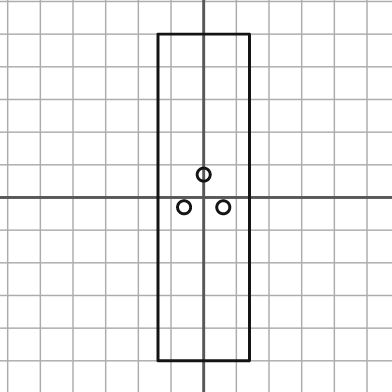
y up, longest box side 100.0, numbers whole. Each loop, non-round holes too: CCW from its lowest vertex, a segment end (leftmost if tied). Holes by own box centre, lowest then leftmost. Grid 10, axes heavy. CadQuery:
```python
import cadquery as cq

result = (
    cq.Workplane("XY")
    .moveTo(-14.0, -50.0)
    .lineTo(14.0, -50.0)
    .lineTo(14.0, 50.0)
    .lineTo(-14.0, 50.0)
    .close()
    .moveTo(-6.0, -3.0)
    .circle(2.0)
    .moveTo(6.0, -3.0)
    .circle(2.0)
    .moveTo(0.0, 7.0)
    .circle(2.0)
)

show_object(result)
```